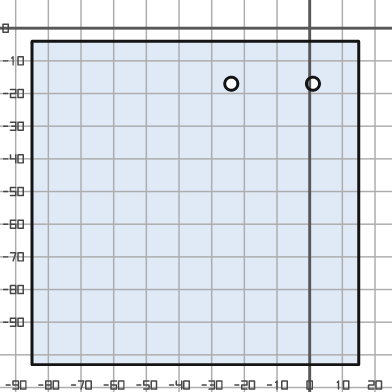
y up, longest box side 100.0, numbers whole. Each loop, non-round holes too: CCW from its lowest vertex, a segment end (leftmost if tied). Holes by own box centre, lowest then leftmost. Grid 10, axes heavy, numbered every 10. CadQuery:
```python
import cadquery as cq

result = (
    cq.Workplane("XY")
    .moveTo(-85.0, -103.0)
    .lineTo(15.0, -103.0)
    .lineTo(15.0, -4.0)
    .lineTo(-85.0, -4.0)
    .close()
    .moveTo(-24.0, -17.0)
    .circle(2.0)
    .moveTo(1.0, -17.0)
    .circle(2.0)
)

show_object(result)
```